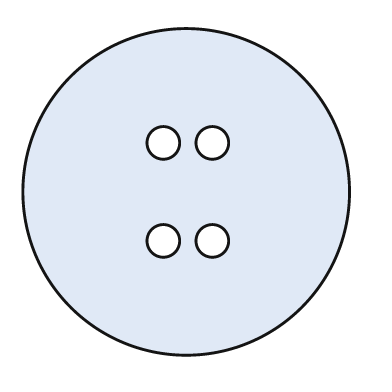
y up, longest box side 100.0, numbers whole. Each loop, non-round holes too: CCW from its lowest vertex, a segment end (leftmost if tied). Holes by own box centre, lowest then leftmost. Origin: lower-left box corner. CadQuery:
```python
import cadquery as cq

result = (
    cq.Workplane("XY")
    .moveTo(50.0, 50.0)
    .circle(50.0)
    .moveTo(43.0, 35.0)
    .circle(5.0)
    .moveTo(58.0, 35.0)
    .circle(5.0)
    .moveTo(43.0, 65.0)
    .circle(5.0)
    .moveTo(58.0, 65.0)
    .circle(5.0)
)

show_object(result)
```